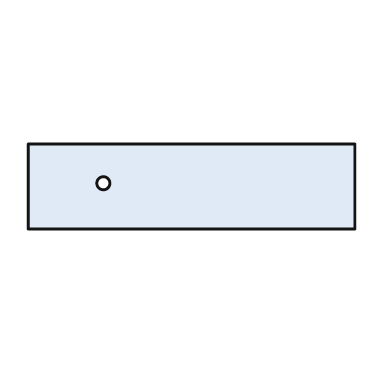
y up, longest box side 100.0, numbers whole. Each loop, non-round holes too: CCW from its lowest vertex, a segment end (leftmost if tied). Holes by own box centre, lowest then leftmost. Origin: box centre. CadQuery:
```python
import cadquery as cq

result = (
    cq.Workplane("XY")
    .moveTo(-50.0, -13.0)
    .lineTo(50.0, -13.0)
    .lineTo(50.0, 13.0)
    .lineTo(-50.0, 13.0)
    .close()
    .moveTo(-27.0, 1.0)
    .circle(2.0)
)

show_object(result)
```